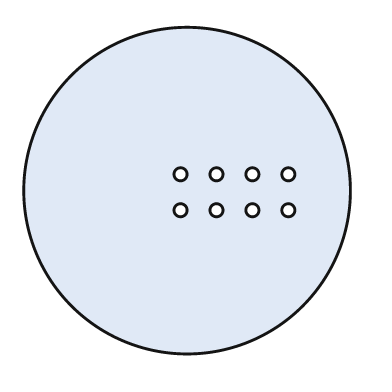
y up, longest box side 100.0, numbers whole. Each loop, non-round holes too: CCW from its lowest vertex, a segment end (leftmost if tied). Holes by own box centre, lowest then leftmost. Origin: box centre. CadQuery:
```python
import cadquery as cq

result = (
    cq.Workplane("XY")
    .moveTo(0.0, 0.0)
    .circle(50.0)
    .moveTo(-2.0, -6.0)
    .circle(2.0)
    .moveTo(9.0, -6.0)
    .circle(2.0)
    .moveTo(20.0, -6.0)
    .circle(2.0)
    .moveTo(31.0, -6.0)
    .circle(2.0)
    .moveTo(-2.0, 5.0)
    .circle(2.0)
    .moveTo(9.0, 5.0)
    .circle(2.0)
    .moveTo(20.0, 5.0)
    .circle(2.0)
    .moveTo(31.0, 5.0)
    .circle(2.0)
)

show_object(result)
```